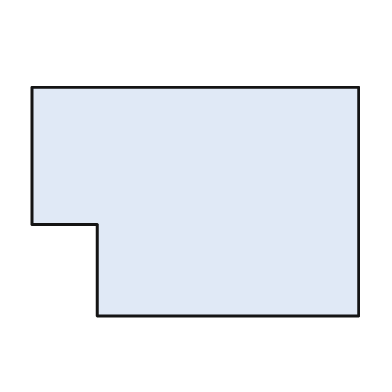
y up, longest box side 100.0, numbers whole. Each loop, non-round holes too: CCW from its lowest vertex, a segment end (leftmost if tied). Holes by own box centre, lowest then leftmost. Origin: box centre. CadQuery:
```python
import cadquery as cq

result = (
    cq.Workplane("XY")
    .moveTo(-30.0, -35.0)
    .lineTo(50.0, -35.0)
    .lineTo(50.0, 35.0)
    .lineTo(-50.0, 35.0)
    .lineTo(-50.0, -7.0)
    .lineTo(-30.0, -7.0)
    .close()
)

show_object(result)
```